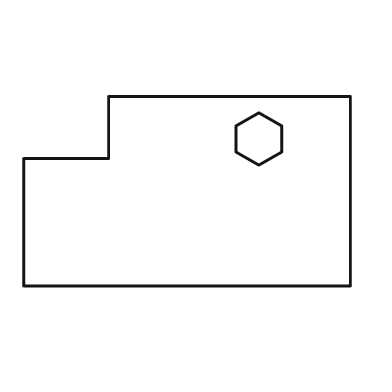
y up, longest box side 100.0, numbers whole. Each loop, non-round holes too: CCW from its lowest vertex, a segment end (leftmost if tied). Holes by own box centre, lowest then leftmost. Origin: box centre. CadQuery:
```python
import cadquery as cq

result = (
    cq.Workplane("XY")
    .moveTo(-50.0, -29.0)
    .lineTo(50.0, -29.0)
    .lineTo(50.0, 29.0)
    .lineTo(-24.0, 29.0)
    .lineTo(-24.0, 10.0)
    .lineTo(-50.0, 10.0)
    .close()
    .moveTo(22.0, 8.0)
    .lineTo(29.0, 12.0)
    .lineTo(29.0, 20.0)
    .lineTo(22.0, 24.0)
    .lineTo(15.0, 20.0)
    .lineTo(15.0, 12.0)
    .close()
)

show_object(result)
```